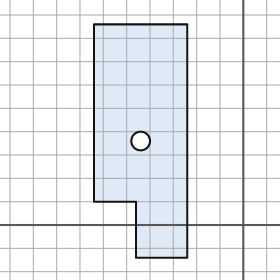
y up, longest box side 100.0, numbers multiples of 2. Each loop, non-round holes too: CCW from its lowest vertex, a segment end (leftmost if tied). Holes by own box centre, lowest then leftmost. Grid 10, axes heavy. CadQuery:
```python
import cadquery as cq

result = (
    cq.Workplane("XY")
    .moveTo(-46.0, -14.0)
    .lineTo(-24.0, -14.0)
    .lineTo(-24.0, 86.0)
    .lineTo(-64.0, 86.0)
    .lineTo(-64.0, 10.0)
    .lineTo(-46.0, 10.0)
    .close()
    .moveTo(-44.0, 36.0)
    .circle(4.0)
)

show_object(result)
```